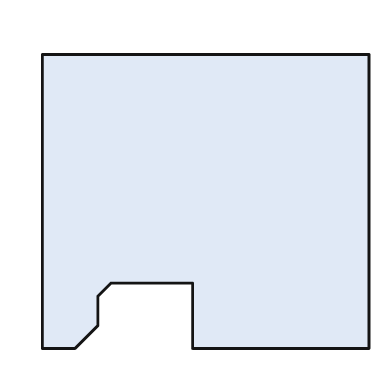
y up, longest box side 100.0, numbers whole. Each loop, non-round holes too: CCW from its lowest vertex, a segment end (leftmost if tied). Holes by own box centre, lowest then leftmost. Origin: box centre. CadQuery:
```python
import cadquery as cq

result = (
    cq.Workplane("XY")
    .moveTo(-50.0, -45.0)
    .lineTo(-40.0, -45.0)
    .lineTo(-33.0, -38.0)
    .lineTo(-33.0, -29.0)
    .lineTo(-29.0, -25.0)
    .lineTo(-4.0, -25.0)
    .lineTo(-4.0, -45.0)
    .lineTo(50.0, -45.0)
    .lineTo(50.0, 45.0)
    .lineTo(-50.0, 45.0)
    .close()
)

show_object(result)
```